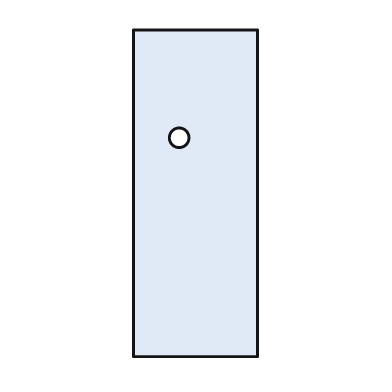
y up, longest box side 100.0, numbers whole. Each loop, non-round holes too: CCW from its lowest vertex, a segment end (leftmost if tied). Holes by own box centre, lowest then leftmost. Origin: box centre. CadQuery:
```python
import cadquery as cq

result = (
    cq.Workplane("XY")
    .moveTo(-19.0, -50.0)
    .lineTo(19.0, -50.0)
    .lineTo(19.0, 50.0)
    .lineTo(-19.0, 50.0)
    .close()
    .moveTo(-5.0, 17.0)
    .circle(3.0)
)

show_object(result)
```